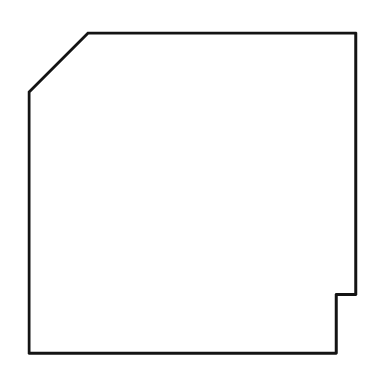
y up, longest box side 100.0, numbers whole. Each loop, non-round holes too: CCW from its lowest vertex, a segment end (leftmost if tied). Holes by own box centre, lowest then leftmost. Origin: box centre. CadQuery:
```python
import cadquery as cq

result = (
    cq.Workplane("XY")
    .moveTo(-50.0, -49.0)
    .lineTo(44.0, -49.0)
    .lineTo(44.0, -31.0)
    .lineTo(50.0, -31.0)
    .lineTo(50.0, 49.0)
    .lineTo(-32.0, 49.0)
    .lineTo(-50.0, 31.0)
    .close()
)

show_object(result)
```